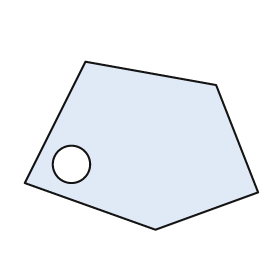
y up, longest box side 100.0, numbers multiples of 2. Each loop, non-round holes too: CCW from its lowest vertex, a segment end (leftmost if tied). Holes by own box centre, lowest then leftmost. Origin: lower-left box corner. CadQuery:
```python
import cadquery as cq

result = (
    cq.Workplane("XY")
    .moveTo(56.0, 0.0)
    .lineTo(100.0, 16.0)
    .lineTo(82.0, 62.0)
    .lineTo(26.0, 72.0)
    .lineTo(0.0, 20.0)
    .close()
    .moveTo(20.0, 28.0)
    .circle(8.0)
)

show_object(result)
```